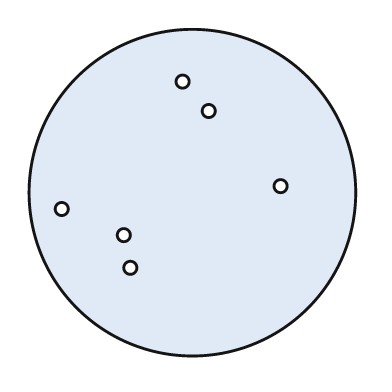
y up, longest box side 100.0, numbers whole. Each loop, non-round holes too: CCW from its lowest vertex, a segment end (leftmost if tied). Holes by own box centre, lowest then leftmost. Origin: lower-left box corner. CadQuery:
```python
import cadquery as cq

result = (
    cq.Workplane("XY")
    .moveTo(50.0, 50.0)
    .circle(50.0)
    .moveTo(31.0, 27.0)
    .circle(2.0)
    .moveTo(29.0, 37.0)
    .circle(2.0)
    .moveTo(10.0, 45.0)
    .circle(2.0)
    .moveTo(77.0, 52.0)
    .circle(2.0)
    .moveTo(55.0, 75.0)
    .circle(2.0)
    .moveTo(47.0, 84.0)
    .circle(2.0)
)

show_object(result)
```